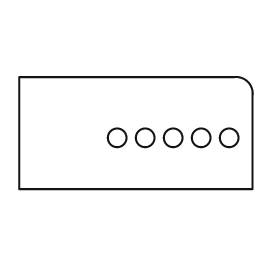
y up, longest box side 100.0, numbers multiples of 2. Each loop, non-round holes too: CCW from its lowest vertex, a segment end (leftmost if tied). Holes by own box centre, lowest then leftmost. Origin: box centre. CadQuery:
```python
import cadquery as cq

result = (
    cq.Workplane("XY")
    .moveTo(-50.0, -24.0)
    .lineTo(50.0, -24.0)
    .lineTo(50.0, 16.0)
    .threePointArc((48.0, 22.0), (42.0, 24.0))
    .lineTo(-50.0, 24.0)
    .close()
    .moveTo(-8.0, -2.0)
    .circle(4.0)
    .moveTo(4.0, -2.0)
    .circle(4.0)
    .moveTo(16.0, -2.0)
    .circle(4.0)
    .moveTo(28.0, -2.0)
    .circle(4.0)
    .moveTo(40.0, -2.0)
    .circle(4.0)
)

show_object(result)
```